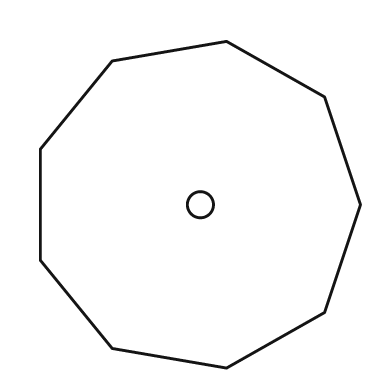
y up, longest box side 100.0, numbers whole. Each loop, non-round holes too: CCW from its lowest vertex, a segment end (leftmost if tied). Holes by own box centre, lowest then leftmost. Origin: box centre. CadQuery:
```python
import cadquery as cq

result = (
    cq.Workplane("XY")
    .moveTo(8.0, -50.0)
    .lineTo(38.0, -33.0)
    .lineTo(49.0, 0.0)
    .lineTo(38.0, 33.0)
    .lineTo(8.0, 50.0)
    .lineTo(-27.0, 44.0)
    .lineTo(-49.0, 17.0)
    .lineTo(-49.0, -17.0)
    .lineTo(-27.0, -44.0)
    .close()
    .moveTo(0.0, 0.0)
    .circle(4.0)
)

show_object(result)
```